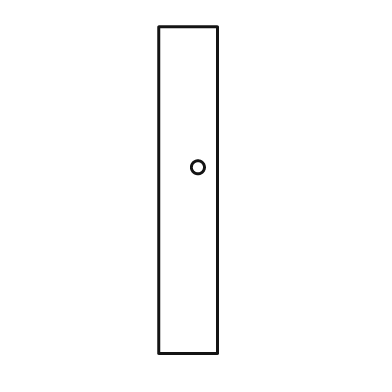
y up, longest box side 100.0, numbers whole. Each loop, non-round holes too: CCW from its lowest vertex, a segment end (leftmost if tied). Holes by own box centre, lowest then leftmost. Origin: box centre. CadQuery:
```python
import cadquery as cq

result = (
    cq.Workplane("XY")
    .moveTo(-9.0, -50.0)
    .lineTo(9.0, -50.0)
    .lineTo(9.0, 50.0)
    .lineTo(-9.0, 50.0)
    .close()
    .moveTo(3.0, 7.0)
    .circle(2.0)
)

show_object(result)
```